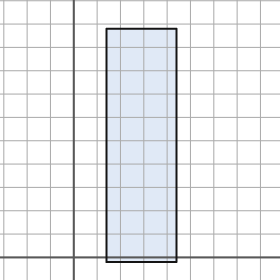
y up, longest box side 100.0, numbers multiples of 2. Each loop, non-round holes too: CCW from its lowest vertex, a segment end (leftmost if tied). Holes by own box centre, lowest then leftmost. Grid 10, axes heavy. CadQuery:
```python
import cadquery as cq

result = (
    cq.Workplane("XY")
    .moveTo(14.0, -2.0)
    .lineTo(44.0, -2.0)
    .lineTo(44.0, 98.0)
    .lineTo(14.0, 98.0)
    .close()
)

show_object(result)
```